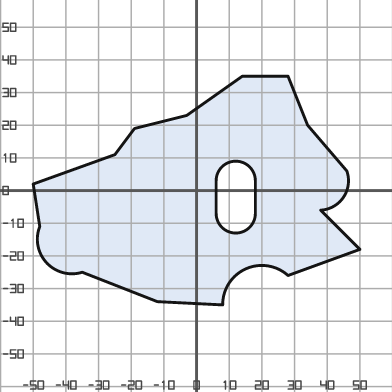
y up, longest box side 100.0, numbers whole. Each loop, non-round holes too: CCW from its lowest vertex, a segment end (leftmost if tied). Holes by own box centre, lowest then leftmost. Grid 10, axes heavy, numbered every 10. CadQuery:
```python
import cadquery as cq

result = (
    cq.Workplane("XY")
    .moveTo(8.0, -35.0)
    .threePointArc((15.0, -24.0), (28.0, -26.0))
    .lineTo(50.0, -18.0)
    .lineTo(38.0, -6.0)
    .threePointArc((45.0, -2.0), (46.0, 6.0))
    .lineTo(34.0, 20.0)
    .lineTo(28.0, 35.0)
    .lineTo(14.0, 35.0)
    .lineTo(-3.0, 23.0)
    .lineTo(-19.0, 19.0)
    .lineTo(-25.0, 11.0)
    .lineTo(-50.0, 2.0)
    .lineTo(-48.0, -11.0)
    .threePointArc((-46.0, -22.0), (-35.0, -25.0))
    .lineTo(-12.0, -34.0)
    .close()
    .moveTo(6.0, -7.0)
    .threePointArc((12.0, -13.0), (18.0, -7.0))
    .lineTo(18.0, 3.0)
    .threePointArc((12.0, 9.0), (6.0, 3.0))
    .close()
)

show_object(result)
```